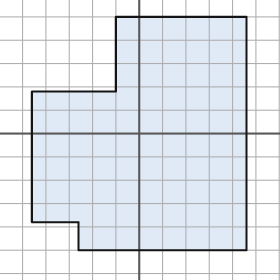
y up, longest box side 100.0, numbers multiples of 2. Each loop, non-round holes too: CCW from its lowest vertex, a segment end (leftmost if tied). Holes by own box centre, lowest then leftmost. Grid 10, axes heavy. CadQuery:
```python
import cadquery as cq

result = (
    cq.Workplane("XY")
    .moveTo(-26.0, -50.0)
    .lineTo(46.0, -50.0)
    .lineTo(46.0, 50.0)
    .lineTo(-10.0, 50.0)
    .lineTo(-10.0, 18.0)
    .lineTo(-46.0, 18.0)
    .lineTo(-46.0, -38.0)
    .lineTo(-26.0, -38.0)
    .close()
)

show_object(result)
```